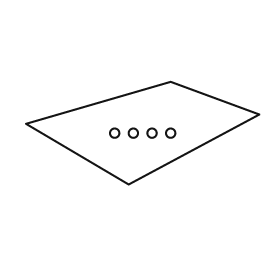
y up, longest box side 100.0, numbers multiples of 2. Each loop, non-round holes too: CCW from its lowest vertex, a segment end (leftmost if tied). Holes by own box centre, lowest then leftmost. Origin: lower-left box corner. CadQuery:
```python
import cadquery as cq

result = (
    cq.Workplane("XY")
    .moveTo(44.0, 0.0)
    .lineTo(100.0, 30.0)
    .lineTo(62.0, 44.0)
    .lineTo(0.0, 26.0)
    .close()
    .moveTo(38.0, 22.0)
    .circle(2.0)
    .moveTo(46.0, 22.0)
    .circle(2.0)
    .moveTo(54.0, 22.0)
    .circle(2.0)
    .moveTo(62.0, 22.0)
    .circle(2.0)
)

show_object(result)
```